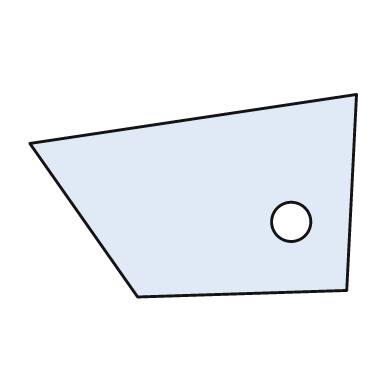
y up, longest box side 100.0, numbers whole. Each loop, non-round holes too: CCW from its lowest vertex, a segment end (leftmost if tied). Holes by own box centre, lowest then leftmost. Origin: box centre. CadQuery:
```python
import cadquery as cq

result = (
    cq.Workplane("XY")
    .moveTo(-17.0, -31.0)
    .lineTo(47.0, -29.0)
    .lineTo(50.0, 31.0)
    .lineTo(-50.0, 16.0)
    .close()
    .moveTo(30.0, -8.0)
    .circle(6.0)
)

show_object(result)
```